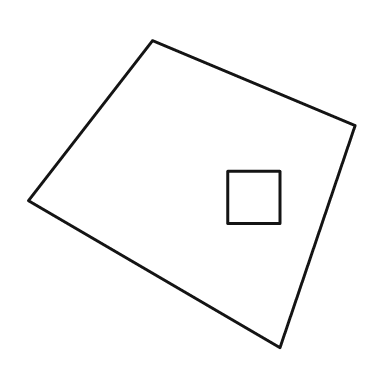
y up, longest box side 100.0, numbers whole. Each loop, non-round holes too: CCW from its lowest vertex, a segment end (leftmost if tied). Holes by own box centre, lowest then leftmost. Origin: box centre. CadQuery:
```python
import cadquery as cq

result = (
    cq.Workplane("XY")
    .moveTo(27.0, -47.0)
    .lineTo(50.0, 21.0)
    .lineTo(-12.0, 47.0)
    .lineTo(-50.0, -2.0)
    .close()
    .moveTo(11.0, -9.0)
    .lineTo(27.0, -9.0)
    .lineTo(27.0, 7.0)
    .lineTo(11.0, 7.0)
    .close()
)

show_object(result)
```